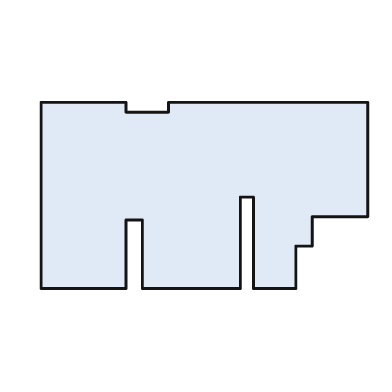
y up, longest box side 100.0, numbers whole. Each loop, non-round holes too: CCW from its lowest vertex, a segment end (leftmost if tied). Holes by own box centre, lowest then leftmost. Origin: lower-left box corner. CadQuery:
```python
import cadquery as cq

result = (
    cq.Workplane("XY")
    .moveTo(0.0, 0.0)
    .lineTo(26.0, 0.0)
    .lineTo(26.0, 21.0)
    .lineTo(31.0, 21.0)
    .lineTo(31.0, 0.0)
    .lineTo(61.0, 0.0)
    .lineTo(61.0, 28.0)
    .lineTo(65.0, 28.0)
    .lineTo(65.0, 0.0)
    .lineTo(78.0, 0.0)
    .lineTo(78.0, 13.0)
    .lineTo(83.0, 13.0)
    .lineTo(83.0, 22.0)
    .lineTo(100.0, 22.0)
    .lineTo(100.0, 57.0)
    .lineTo(39.0, 57.0)
    .lineTo(39.0, 54.0)
    .lineTo(26.0, 54.0)
    .lineTo(26.0, 57.0)
    .lineTo(0.0, 57.0)
    .close()
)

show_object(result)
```